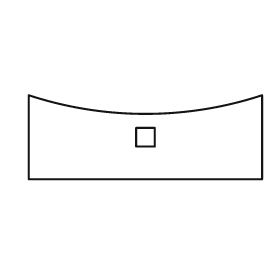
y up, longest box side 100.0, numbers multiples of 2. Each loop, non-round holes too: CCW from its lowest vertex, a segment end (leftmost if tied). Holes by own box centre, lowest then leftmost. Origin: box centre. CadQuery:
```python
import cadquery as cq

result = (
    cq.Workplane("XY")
    .moveTo(-50.0, -18.0)
    .lineTo(50.0, -18.0)
    .lineTo(50.0, 18.0)
    .threePointArc((0.0, 10.0), (-50.0, 18.0))
    .close()
    .moveTo(-4.0, -4.0)
    .lineTo(4.0, -4.0)
    .lineTo(4.0, 4.0)
    .lineTo(-4.0, 4.0)
    .close()
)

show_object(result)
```